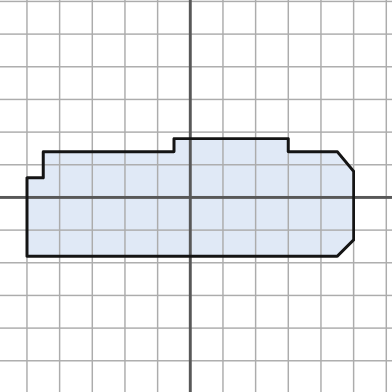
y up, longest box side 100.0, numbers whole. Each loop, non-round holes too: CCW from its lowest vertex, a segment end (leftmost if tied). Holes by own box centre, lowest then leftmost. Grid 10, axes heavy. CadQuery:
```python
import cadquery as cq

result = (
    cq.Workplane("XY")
    .moveTo(-50.0, -18.0)
    .lineTo(45.0, -18.0)
    .lineTo(50.0, -13.0)
    .lineTo(50.0, 8.0)
    .lineTo(45.0, 14.0)
    .lineTo(30.0, 14.0)
    .lineTo(30.0, 18.0)
    .lineTo(-5.0, 18.0)
    .lineTo(-5.0, 14.0)
    .lineTo(-45.0, 14.0)
    .lineTo(-45.0, 6.0)
    .lineTo(-50.0, 6.0)
    .close()
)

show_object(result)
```